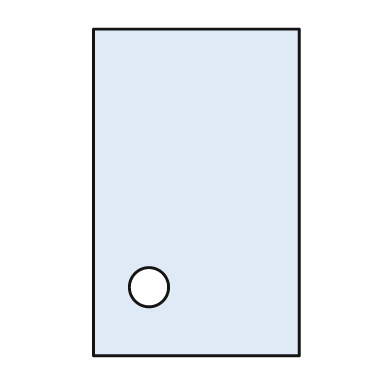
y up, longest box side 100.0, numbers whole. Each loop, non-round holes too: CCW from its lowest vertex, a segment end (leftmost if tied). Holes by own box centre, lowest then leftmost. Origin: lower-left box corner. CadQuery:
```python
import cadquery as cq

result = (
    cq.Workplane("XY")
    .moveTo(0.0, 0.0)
    .lineTo(63.0, 0.0)
    .lineTo(63.0, 100.0)
    .lineTo(0.0, 100.0)
    .close()
    .moveTo(17.0, 21.0)
    .circle(6.0)
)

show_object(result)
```